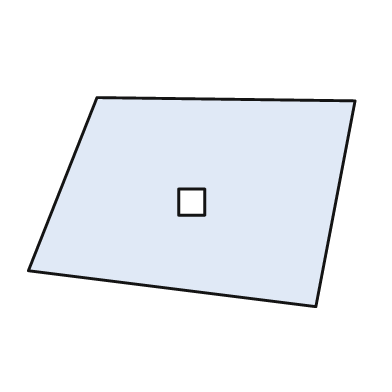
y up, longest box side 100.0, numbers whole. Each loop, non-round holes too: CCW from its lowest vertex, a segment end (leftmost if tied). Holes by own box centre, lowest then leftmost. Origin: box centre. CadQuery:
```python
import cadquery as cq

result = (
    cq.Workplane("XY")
    .moveTo(38.0, -32.0)
    .lineTo(50.0, 31.0)
    .lineTo(-29.0, 32.0)
    .lineTo(-50.0, -21.0)
    .close()
    .moveTo(-4.0, -4.0)
    .lineTo(4.0, -4.0)
    .lineTo(4.0, 4.0)
    .lineTo(-4.0, 4.0)
    .close()
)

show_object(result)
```